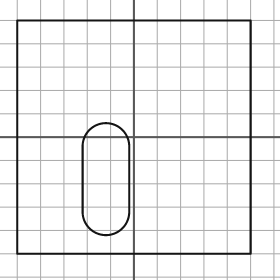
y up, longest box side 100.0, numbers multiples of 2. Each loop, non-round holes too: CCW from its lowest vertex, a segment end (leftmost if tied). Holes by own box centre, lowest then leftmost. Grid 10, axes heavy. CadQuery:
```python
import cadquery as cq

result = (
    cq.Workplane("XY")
    .moveTo(-50.0, -50.0)
    .lineTo(50.0, -50.0)
    .lineTo(50.0, 50.0)
    .lineTo(-50.0, 50.0)
    .close()
    .moveTo(-22.0, -32.0)
    .threePointArc((-12.0, -42.0), (-2.0, -32.0))
    .lineTo(-2.0, -4.0)
    .threePointArc((-12.0, 6.0), (-22.0, -4.0))
    .close()
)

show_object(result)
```